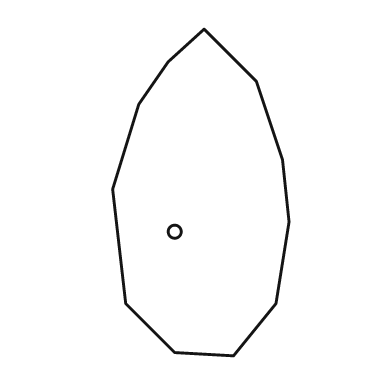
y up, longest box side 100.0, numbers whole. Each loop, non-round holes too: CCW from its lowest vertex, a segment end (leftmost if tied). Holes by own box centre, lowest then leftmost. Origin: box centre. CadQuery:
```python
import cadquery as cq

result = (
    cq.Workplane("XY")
    .moveTo(10.0, -50.0)
    .lineTo(23.0, -34.0)
    .lineTo(27.0, -9.0)
    .lineTo(25.0, 10.0)
    .lineTo(17.0, 34.0)
    .lineTo(1.0, 50.0)
    .lineTo(-10.0, 40.0)
    .lineTo(-19.0, 27.0)
    .lineTo(-27.0, 1.0)
    .lineTo(-23.0, -34.0)
    .lineTo(-8.0, -49.0)
    .close()
    .moveTo(-8.0, -12.0)
    .circle(2.0)
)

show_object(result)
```